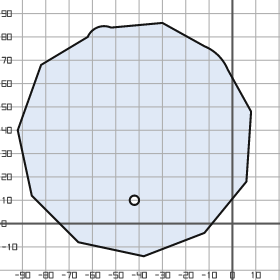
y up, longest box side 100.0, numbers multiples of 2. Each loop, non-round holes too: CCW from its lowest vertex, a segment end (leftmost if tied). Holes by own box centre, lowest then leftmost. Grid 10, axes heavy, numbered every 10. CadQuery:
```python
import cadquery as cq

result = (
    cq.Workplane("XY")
    .moveTo(-38.0, -14.0)
    .lineTo(-12.0, -4.0)
    .lineTo(6.0, 18.0)
    .lineTo(8.0, 48.0)
    .lineTo(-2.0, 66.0)
    .threePointArc((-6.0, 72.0), (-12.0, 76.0))
    .lineTo(-30.0, 86.0)
    .lineTo(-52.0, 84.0)
    .threePointArc((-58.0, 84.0), (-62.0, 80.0))
    .lineTo(-82.0, 68.0)
    .lineTo(-92.0, 40.0)
    .lineTo(-86.0, 12.0)
    .lineTo(-66.0, -8.0)
    .close()
    .moveTo(-42.0, 10.0)
    .circle(2.0)
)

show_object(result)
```